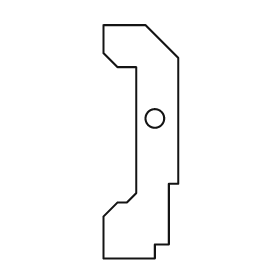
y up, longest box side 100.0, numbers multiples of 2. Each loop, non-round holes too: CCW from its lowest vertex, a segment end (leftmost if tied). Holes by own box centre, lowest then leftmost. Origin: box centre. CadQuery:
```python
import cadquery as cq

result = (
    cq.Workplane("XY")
    .moveTo(-16.0, -50.0)
    .lineTo(6.0, -50.0)
    .lineTo(6.0, -44.0)
    .lineTo(12.0, -44.0)
    .lineTo(12.0, -18.0)
    .lineTo(16.0, -18.0)
    .lineTo(16.0, 36.0)
    .lineTo(2.0, 50.0)
    .lineTo(-16.0, 50.0)
    .lineTo(-16.0, 38.0)
    .lineTo(-10.0, 32.0)
    .lineTo(-2.0, 32.0)
    .lineTo(-2.0, -22.0)
    .lineTo(-6.0, -26.0)
    .lineTo(-10.0, -26.0)
    .lineTo(-16.0, -32.0)
    .close()
    .moveTo(6.0, 10.0)
    .circle(4.0)
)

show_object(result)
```